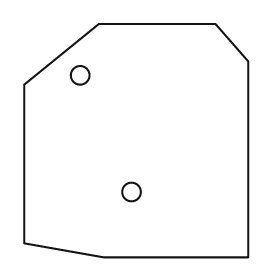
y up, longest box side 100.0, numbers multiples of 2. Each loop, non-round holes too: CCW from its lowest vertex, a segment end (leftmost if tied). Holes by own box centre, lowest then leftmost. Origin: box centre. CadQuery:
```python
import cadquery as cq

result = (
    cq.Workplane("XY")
    .moveTo(-14.0, -50.0)
    .lineTo(48.0, -50.0)
    .lineTo(48.0, 34.0)
    .lineTo(34.0, 50.0)
    .lineTo(-16.0, 50.0)
    .lineTo(-48.0, 24.0)
    .lineTo(-48.0, -44.0)
    .close()
    .moveTo(-2.0, -22.0)
    .circle(4.0)
    .moveTo(-24.0, 28.0)
    .circle(4.0)
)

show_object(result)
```